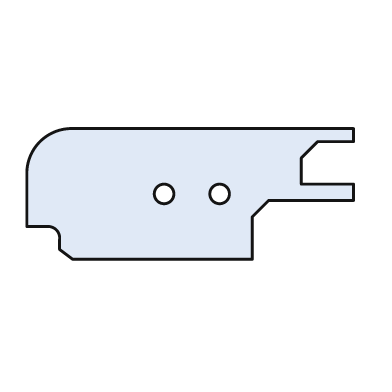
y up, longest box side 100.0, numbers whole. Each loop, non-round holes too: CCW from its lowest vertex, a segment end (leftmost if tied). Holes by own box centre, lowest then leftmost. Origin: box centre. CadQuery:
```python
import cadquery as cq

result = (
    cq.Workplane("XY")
    .moveTo(-36.0, -20.0)
    .lineTo(19.0, -20.0)
    .lineTo(19.0, -7.0)
    .lineTo(24.0, -2.0)
    .lineTo(50.0, -2.0)
    .lineTo(50.0, 3.0)
    .lineTo(34.0, 3.0)
    .lineTo(34.0, 11.0)
    .lineTo(39.0, 16.0)
    .lineTo(50.0, 16.0)
    .lineTo(50.0, 20.0)
    .lineTo(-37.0, 20.0)
    .threePointArc((-46.0, 16.0), (-50.0, 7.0))
    .lineTo(-50.0, -10.0)
    .lineTo(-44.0, -10.0)
    .threePointArc((-41.0, -11.0), (-40.0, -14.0))
    .lineTo(-40.0, -17.0)
    .close()
    .moveTo(-8.0, 0.0)
    .circle(3.0)
    .moveTo(9.0, 0.0)
    .circle(3.0)
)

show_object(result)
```